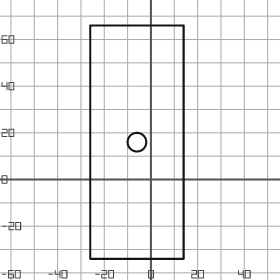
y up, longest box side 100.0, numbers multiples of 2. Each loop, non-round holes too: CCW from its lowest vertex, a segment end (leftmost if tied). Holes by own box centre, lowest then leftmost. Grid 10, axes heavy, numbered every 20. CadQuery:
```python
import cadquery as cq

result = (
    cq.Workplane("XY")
    .moveTo(-26.0, -34.0)
    .lineTo(14.0, -34.0)
    .lineTo(14.0, 66.0)
    .lineTo(-26.0, 66.0)
    .close()
    .moveTo(-6.0, 16.0)
    .circle(4.0)
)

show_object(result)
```